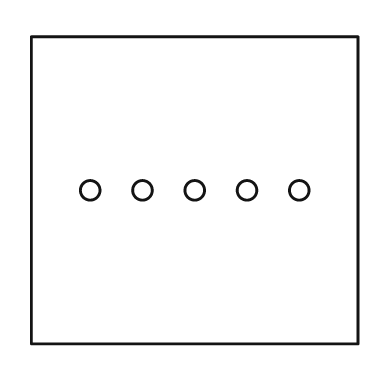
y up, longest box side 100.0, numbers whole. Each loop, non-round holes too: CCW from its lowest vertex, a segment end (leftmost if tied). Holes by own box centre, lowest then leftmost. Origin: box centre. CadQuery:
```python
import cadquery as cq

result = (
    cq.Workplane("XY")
    .moveTo(-50.0, -47.0)
    .lineTo(50.0, -47.0)
    .lineTo(50.0, 47.0)
    .lineTo(-50.0, 47.0)
    .close()
    .moveTo(-32.0, 0.0)
    .circle(3.0)
    .moveTo(-16.0, 0.0)
    .circle(3.0)
    .moveTo(0.0, 0.0)
    .circle(3.0)
    .moveTo(16.0, 0.0)
    .circle(3.0)
    .moveTo(32.0, 0.0)
    .circle(3.0)
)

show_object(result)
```